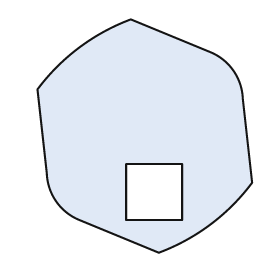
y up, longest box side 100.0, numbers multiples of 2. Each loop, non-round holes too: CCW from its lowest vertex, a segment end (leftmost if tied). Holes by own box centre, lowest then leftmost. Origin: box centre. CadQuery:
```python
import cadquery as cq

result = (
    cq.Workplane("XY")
    .moveTo(6.0, -50.0)
    .threePointArc((28.0, -38.0), (46.0, -20.0))
    .lineTo(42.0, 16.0)
    .threePointArc((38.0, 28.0), (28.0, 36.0))
    .lineTo(-6.0, 50.0)
    .threePointArc((-28.0, 38.0), (-46.0, 20.0))
    .lineTo(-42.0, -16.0)
    .threePointArc((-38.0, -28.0), (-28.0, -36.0))
    .close()
    .moveTo(-8.0, -36.0)
    .lineTo(16.0, -36.0)
    .lineTo(16.0, -12.0)
    .lineTo(-8.0, -12.0)
    .close()
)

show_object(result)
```